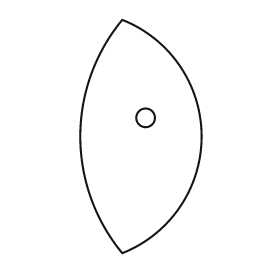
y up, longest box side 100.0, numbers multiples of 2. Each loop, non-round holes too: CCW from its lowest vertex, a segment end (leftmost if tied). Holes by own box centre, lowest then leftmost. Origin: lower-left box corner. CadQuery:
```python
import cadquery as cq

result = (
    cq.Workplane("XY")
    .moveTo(18.0, 0.0)
    .threePointArc((52.0, 50.0), (18.0, 100.0))
    .threePointArc((0.0, 50.0), (18.0, 0.0))
    .close()
    .moveTo(28.0, 58.0)
    .circle(4.0)
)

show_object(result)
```